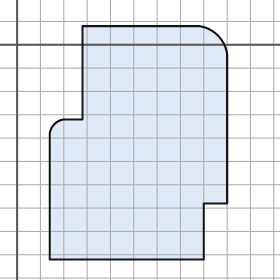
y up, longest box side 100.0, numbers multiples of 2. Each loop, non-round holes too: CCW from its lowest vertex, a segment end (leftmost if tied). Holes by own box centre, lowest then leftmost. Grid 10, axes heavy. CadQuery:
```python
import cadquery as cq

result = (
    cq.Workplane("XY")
    .moveTo(14.0, -92.0)
    .lineTo(80.0, -92.0)
    .lineTo(80.0, -68.0)
    .lineTo(90.0, -68.0)
    .lineTo(90.0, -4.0)
    .threePointArc((86.0, 4.0), (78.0, 8.0))
    .lineTo(28.0, 8.0)
    .lineTo(28.0, -32.0)
    .lineTo(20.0, -32.0)
    .threePointArc((16.0, -34.0), (14.0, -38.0))
    .close()
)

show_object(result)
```